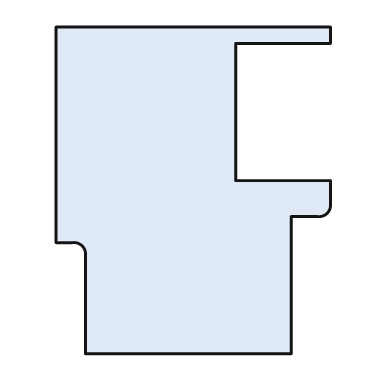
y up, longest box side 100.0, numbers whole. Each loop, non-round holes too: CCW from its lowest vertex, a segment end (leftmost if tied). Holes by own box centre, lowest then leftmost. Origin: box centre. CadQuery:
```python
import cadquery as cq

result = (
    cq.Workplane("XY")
    .moveTo(-33.0, -50.0)
    .lineTo(30.0, -50.0)
    .lineTo(30.0, -8.0)
    .lineTo(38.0, -8.0)
    .threePointArc((41.0, -7.0), (42.0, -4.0))
    .lineTo(42.0, 3.0)
    .lineTo(13.0, 3.0)
    .lineTo(13.0, 45.0)
    .lineTo(42.0, 45.0)
    .lineTo(42.0, 50.0)
    .lineTo(-42.0, 50.0)
    .lineTo(-42.0, -16.0)
    .lineTo(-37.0, -16.0)
    .threePointArc((-34.0, -17.0), (-33.0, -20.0))
    .close()
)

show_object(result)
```